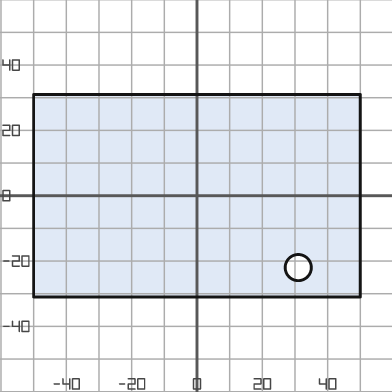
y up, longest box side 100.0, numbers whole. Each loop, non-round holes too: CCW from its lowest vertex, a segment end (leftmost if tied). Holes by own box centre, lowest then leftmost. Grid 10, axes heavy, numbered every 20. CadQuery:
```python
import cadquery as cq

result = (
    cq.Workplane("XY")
    .moveTo(-50.0, -31.0)
    .lineTo(50.0, -31.0)
    .lineTo(50.0, 31.0)
    .lineTo(-50.0, 31.0)
    .close()
    .moveTo(31.0, -22.0)
    .circle(4.0)
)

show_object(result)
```